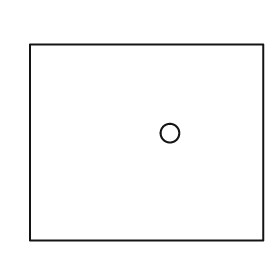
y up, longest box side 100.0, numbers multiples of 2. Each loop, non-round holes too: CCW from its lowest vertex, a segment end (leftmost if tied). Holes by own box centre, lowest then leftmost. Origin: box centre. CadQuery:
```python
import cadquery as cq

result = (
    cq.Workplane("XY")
    .moveTo(-50.0, -42.0)
    .lineTo(50.0, -42.0)
    .lineTo(50.0, 42.0)
    .lineTo(-50.0, 42.0)
    .close()
    .moveTo(10.0, 4.0)
    .circle(4.0)
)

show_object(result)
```